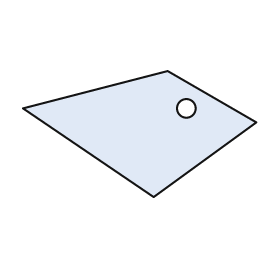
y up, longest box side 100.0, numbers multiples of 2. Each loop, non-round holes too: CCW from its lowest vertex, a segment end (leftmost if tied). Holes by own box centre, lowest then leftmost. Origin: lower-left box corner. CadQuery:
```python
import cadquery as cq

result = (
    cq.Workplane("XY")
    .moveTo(56.0, 0.0)
    .lineTo(100.0, 32.0)
    .lineTo(62.0, 54.0)
    .lineTo(0.0, 38.0)
    .close()
    .moveTo(70.0, 38.0)
    .circle(4.0)
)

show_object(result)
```